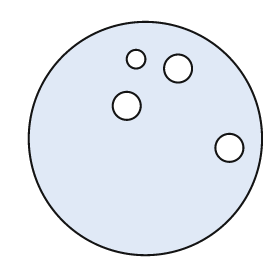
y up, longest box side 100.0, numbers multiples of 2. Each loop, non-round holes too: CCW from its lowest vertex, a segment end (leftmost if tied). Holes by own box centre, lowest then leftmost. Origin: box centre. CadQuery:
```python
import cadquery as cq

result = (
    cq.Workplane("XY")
    .moveTo(0.0, 0.0)
    .circle(50.0)
    .moveTo(36.0, -4.0)
    .circle(6.0)
    .moveTo(-8.0, 14.0)
    .circle(6.0)
    .moveTo(14.0, 30.0)
    .circle(6.0)
    .moveTo(-4.0, 34.0)
    .circle(4.0)
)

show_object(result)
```